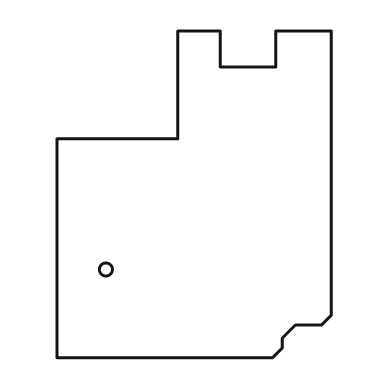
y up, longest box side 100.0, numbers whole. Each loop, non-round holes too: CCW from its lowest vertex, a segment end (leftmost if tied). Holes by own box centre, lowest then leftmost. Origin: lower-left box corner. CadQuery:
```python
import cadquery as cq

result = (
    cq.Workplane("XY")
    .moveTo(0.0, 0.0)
    .lineTo(66.0, 0.0)
    .lineTo(69.0, 3.0)
    .lineTo(69.0, 6.0)
    .lineTo(73.0, 10.0)
    .lineTo(81.0, 10.0)
    .lineTo(84.0, 13.0)
    .lineTo(84.0, 100.0)
    .lineTo(67.0, 100.0)
    .lineTo(67.0, 89.0)
    .lineTo(50.0, 89.0)
    .lineTo(50.0, 100.0)
    .lineTo(37.0, 100.0)
    .lineTo(37.0, 67.0)
    .lineTo(0.0, 67.0)
    .close()
    .moveTo(15.0, 27.0)
    .circle(2.0)
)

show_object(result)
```